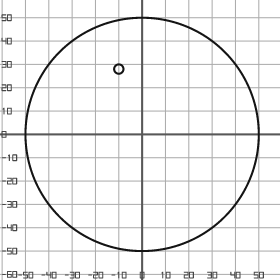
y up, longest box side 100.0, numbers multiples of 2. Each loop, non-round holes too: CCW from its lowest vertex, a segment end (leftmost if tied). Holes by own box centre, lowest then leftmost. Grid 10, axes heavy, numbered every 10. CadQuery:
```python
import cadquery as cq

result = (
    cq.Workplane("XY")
    .moveTo(0.0, 0.0)
    .circle(50.0)
    .moveTo(-10.0, 28.0)
    .circle(2.0)
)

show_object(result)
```